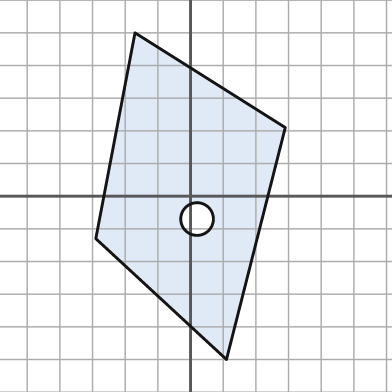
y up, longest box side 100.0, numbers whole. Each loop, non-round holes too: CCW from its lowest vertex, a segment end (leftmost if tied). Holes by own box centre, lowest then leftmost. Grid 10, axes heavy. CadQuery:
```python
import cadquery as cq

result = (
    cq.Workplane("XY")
    .moveTo(11.0, -50.0)
    .lineTo(29.0, 21.0)
    .lineTo(-17.0, 50.0)
    .lineTo(-29.0, -13.0)
    .close()
    .moveTo(2.0, -7.0)
    .circle(5.0)
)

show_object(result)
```